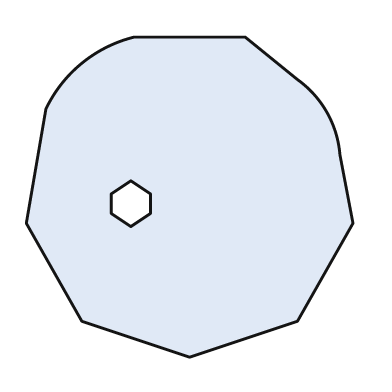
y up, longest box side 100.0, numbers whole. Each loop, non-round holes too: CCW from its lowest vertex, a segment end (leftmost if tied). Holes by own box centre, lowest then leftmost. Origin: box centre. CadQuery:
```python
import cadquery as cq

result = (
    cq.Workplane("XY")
    .moveTo(0.0, -49.0)
    .lineTo(33.0, -38.0)
    .lineTo(50.0, -8.0)
    .lineTo(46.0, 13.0)
    .threePointArc((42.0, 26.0), (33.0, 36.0))
    .lineTo(17.0, 49.0)
    .lineTo(-17.0, 49.0)
    .threePointArc((-33.0, 41.0), (-44.0, 27.0))
    .lineTo(-50.0, -8.0)
    .lineTo(-33.0, -38.0)
    .close()
    .moveTo(-18.0, -9.0)
    .lineTo(-12.0, -5.0)
    .lineTo(-12.0, 1.0)
    .lineTo(-18.0, 5.0)
    .lineTo(-24.0, 1.0)
    .lineTo(-24.0, -5.0)
    .close()
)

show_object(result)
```